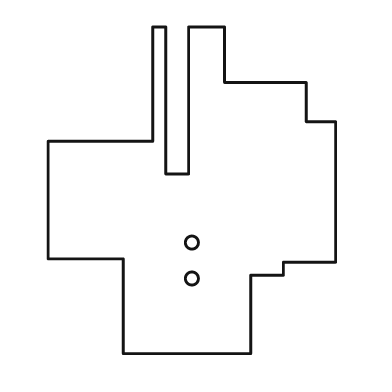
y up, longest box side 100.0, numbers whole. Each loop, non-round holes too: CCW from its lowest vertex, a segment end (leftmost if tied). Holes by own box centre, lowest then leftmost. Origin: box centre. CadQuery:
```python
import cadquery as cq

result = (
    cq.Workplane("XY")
    .moveTo(-21.0, -50.0)
    .lineTo(18.0, -50.0)
    .lineTo(18.0, -26.0)
    .lineTo(28.0, -26.0)
    .lineTo(28.0, -22.0)
    .lineTo(44.0, -22.0)
    .lineTo(44.0, 21.0)
    .lineTo(35.0, 21.0)
    .lineTo(35.0, 33.0)
    .lineTo(10.0, 33.0)
    .lineTo(10.0, 50.0)
    .lineTo(-1.0, 50.0)
    .lineTo(-1.0, 5.0)
    .lineTo(-8.0, 5.0)
    .lineTo(-8.0, 50.0)
    .lineTo(-12.0, 50.0)
    .lineTo(-12.0, 15.0)
    .lineTo(-44.0, 15.0)
    .lineTo(-44.0, -21.0)
    .lineTo(-21.0, -21.0)
    .close()
    .moveTo(0.0, -27.0)
    .circle(2.0)
    .moveTo(0.0, -16.0)
    .circle(2.0)
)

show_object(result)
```